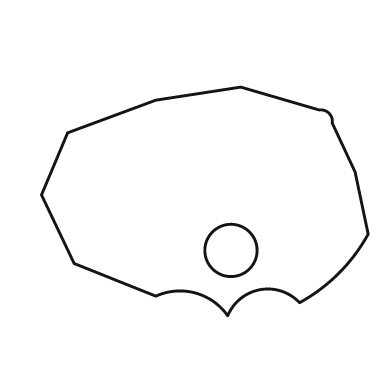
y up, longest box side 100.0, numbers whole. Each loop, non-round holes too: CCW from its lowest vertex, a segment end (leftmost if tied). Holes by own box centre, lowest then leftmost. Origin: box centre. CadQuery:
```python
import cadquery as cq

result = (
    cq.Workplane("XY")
    .moveTo(7.0, -35.0)
    .threePointArc((17.0, -27.0), (29.0, -31.0))
    .threePointArc((41.0, -22.0), (50.0, -10.0))
    .lineTo(46.0, 9.0)
    .lineTo(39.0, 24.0)
    .threePointArc((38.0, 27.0), (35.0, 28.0))
    .lineTo(11.0, 35.0)
    .lineTo(-15.0, 31.0)
    .lineTo(-42.0, 21.0)
    .lineTo(-50.0, 2.0)
    .lineTo(-40.0, -19.0)
    .lineTo(-15.0, -29.0)
    .threePointArc((-3.0, -28.0), (7.0, -35.0))
    .close()
    .moveTo(8.0, -15.0)
    .circle(8.0)
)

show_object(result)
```